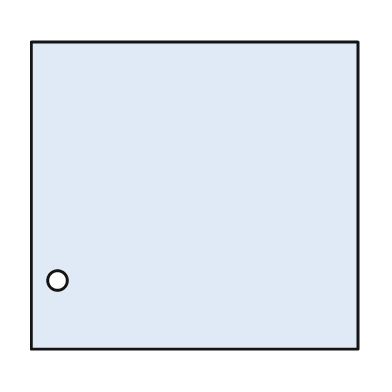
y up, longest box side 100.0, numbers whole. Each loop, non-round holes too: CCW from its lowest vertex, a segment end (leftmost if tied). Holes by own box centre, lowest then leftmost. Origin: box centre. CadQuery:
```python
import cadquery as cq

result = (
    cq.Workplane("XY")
    .moveTo(-50.0, -47.0)
    .lineTo(50.0, -47.0)
    .lineTo(50.0, 47.0)
    .lineTo(-50.0, 47.0)
    .close()
    .moveTo(-42.0, -26.0)
    .circle(3.0)
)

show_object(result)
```